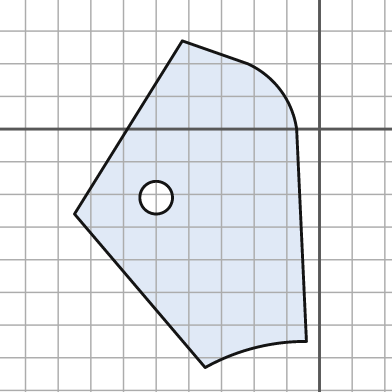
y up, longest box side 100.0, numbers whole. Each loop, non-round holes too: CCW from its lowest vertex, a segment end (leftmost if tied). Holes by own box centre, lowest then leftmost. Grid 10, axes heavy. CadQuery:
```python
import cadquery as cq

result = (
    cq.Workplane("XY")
    .moveTo(-35.0, -73.0)
    .threePointArc((-20.0, -67.0), (-4.0, -65.0))
    .lineTo(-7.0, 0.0)
    .threePointArc((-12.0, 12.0), (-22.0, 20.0))
    .lineTo(-42.0, 27.0)
    .lineTo(-75.0, -26.0)
    .close()
    .moveTo(-50.0, -21.0)
    .circle(5.0)
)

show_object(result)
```